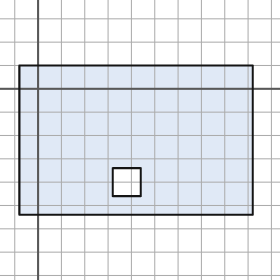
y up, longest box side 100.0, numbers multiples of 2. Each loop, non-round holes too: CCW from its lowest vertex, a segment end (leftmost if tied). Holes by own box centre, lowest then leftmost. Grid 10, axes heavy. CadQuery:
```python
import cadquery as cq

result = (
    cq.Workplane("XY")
    .moveTo(-8.0, -54.0)
    .lineTo(92.0, -54.0)
    .lineTo(92.0, 10.0)
    .lineTo(-8.0, 10.0)
    .close()
    .moveTo(32.0, -46.0)
    .lineTo(44.0, -46.0)
    .lineTo(44.0, -34.0)
    .lineTo(32.0, -34.0)
    .close()
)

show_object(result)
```